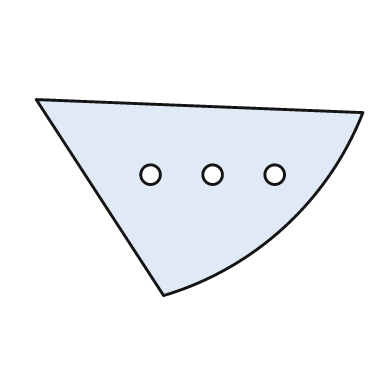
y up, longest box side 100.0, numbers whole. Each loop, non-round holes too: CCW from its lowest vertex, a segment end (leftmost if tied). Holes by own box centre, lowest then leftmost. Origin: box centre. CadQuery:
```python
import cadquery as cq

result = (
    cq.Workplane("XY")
    .moveTo(-11.0, -30.0)
    .threePointArc((26.0, -9.0), (50.0, 26.0))
    .lineTo(-50.0, 30.0)
    .close()
    .moveTo(-15.0, 7.0)
    .circle(3.0)
    .moveTo(4.0, 7.0)
    .circle(3.0)
    .moveTo(23.0, 7.0)
    .circle(3.0)
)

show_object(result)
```